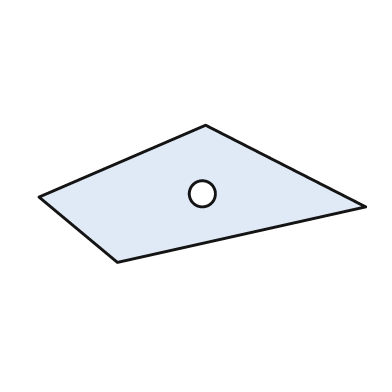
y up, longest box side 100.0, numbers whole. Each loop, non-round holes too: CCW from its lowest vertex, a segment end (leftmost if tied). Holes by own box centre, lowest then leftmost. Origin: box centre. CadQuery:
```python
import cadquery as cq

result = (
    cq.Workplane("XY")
    .moveTo(-26.0, -21.0)
    .lineTo(50.0, -4.0)
    .lineTo(1.0, 21.0)
    .lineTo(-50.0, -1.0)
    .close()
    .moveTo(0.0, 0.0)
    .circle(4.0)
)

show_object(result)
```